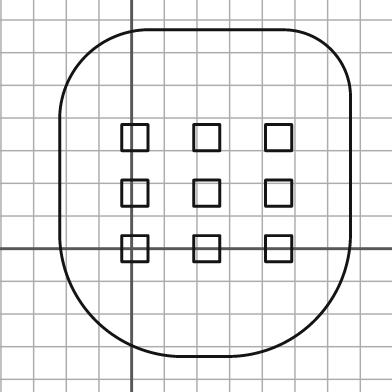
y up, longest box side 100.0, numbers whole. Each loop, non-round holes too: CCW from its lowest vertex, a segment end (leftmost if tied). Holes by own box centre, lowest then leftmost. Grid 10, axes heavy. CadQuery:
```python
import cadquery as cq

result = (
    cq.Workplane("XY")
    .moveTo(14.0, -33.0)
    .lineTo(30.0, -33.0)
    .threePointArc((56.0, -22.0), (67.0, 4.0))
    .lineTo(67.0, 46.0)
    .threePointArc((61.0, 61.0), (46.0, 67.0))
    .lineTo(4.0, 67.0)
    .threePointArc((-14.0, 59.0), (-22.0, 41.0))
    .lineTo(-22.0, 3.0)
    .threePointArc((-11.0, -22.0), (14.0, -33.0))
    .close()
    .moveTo(-3.0, -4.0)
    .lineTo(5.0, -4.0)
    .lineTo(5.0, 4.0)
    .lineTo(-3.0, 4.0)
    .close()
    .moveTo(19.0, -4.0)
    .lineTo(27.0, -4.0)
    .lineTo(27.0, 4.0)
    .lineTo(19.0, 4.0)
    .close()
    .moveTo(41.0, -4.0)
    .lineTo(49.0, -4.0)
    .lineTo(49.0, 4.0)
    .lineTo(41.0, 4.0)
    .close()
    .moveTo(-3.0, 13.0)
    .lineTo(5.0, 13.0)
    .lineTo(5.0, 21.0)
    .lineTo(-3.0, 21.0)
    .close()
    .moveTo(19.0, 13.0)
    .lineTo(27.0, 13.0)
    .lineTo(27.0, 21.0)
    .lineTo(19.0, 21.0)
    .close()
    .moveTo(41.0, 13.0)
    .lineTo(49.0, 13.0)
    .lineTo(49.0, 21.0)
    .lineTo(41.0, 21.0)
    .close()
    .moveTo(-3.0, 30.0)
    .lineTo(5.0, 30.0)
    .lineTo(5.0, 38.0)
    .lineTo(-3.0, 38.0)
    .close()
    .moveTo(19.0, 30.0)
    .lineTo(27.0, 30.0)
    .lineTo(27.0, 38.0)
    .lineTo(19.0, 38.0)
    .close()
    .moveTo(41.0, 30.0)
    .lineTo(49.0, 30.0)
    .lineTo(49.0, 38.0)
    .lineTo(41.0, 38.0)
    .close()
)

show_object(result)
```